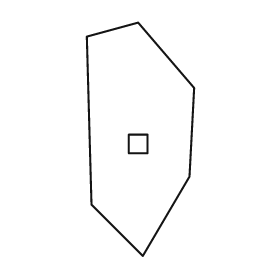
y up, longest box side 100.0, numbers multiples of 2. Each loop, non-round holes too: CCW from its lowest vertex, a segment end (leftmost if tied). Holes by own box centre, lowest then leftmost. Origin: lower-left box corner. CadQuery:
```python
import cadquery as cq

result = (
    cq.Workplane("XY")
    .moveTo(24.0, 0.0)
    .lineTo(44.0, 34.0)
    .lineTo(46.0, 72.0)
    .lineTo(22.0, 100.0)
    .lineTo(0.0, 94.0)
    .lineTo(2.0, 22.0)
    .close()
    .moveTo(18.0, 44.0)
    .lineTo(26.0, 44.0)
    .lineTo(26.0, 52.0)
    .lineTo(18.0, 52.0)
    .close()
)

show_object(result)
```